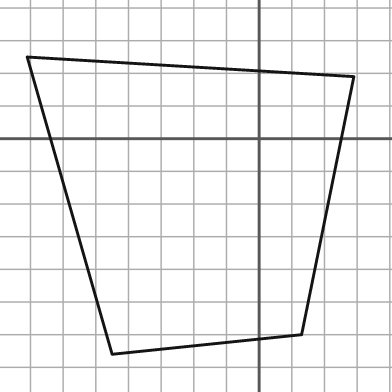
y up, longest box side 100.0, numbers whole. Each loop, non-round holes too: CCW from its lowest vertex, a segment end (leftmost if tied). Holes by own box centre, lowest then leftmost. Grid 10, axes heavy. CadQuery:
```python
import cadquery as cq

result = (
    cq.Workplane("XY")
    .moveTo(-45.0, -66.0)
    .lineTo(13.0, -60.0)
    .lineTo(29.0, 19.0)
    .lineTo(-71.0, 25.0)
    .close()
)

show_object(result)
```